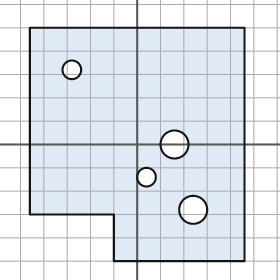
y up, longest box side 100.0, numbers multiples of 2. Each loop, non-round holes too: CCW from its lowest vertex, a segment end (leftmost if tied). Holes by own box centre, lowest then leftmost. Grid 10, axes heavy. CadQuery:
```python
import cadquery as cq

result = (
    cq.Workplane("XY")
    .moveTo(-10.0, -50.0)
    .lineTo(46.0, -50.0)
    .lineTo(46.0, 50.0)
    .lineTo(-46.0, 50.0)
    .lineTo(-46.0, -30.0)
    .lineTo(-10.0, -30.0)
    .close()
    .moveTo(24.0, -28.0)
    .circle(6.0)
    .moveTo(4.0, -14.0)
    .circle(4.0)
    .moveTo(16.0, 0.0)
    .circle(6.0)
    .moveTo(-28.0, 32.0)
    .circle(4.0)
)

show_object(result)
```